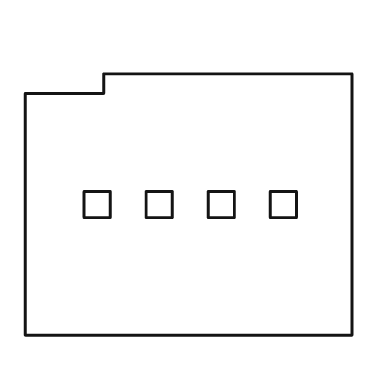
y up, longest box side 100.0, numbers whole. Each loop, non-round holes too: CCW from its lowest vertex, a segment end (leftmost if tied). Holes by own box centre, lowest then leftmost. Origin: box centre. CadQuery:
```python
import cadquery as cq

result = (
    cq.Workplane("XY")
    .moveTo(-50.0, -40.0)
    .lineTo(50.0, -40.0)
    .lineTo(50.0, 40.0)
    .lineTo(-26.0, 40.0)
    .lineTo(-26.0, 34.0)
    .lineTo(-50.0, 34.0)
    .close()
    .moveTo(-32.0, -4.0)
    .lineTo(-24.0, -4.0)
    .lineTo(-24.0, 4.0)
    .lineTo(-32.0, 4.0)
    .close()
    .moveTo(-13.0, -4.0)
    .lineTo(-5.0, -4.0)
    .lineTo(-5.0, 4.0)
    .lineTo(-13.0, 4.0)
    .close()
    .moveTo(6.0, -4.0)
    .lineTo(14.0, -4.0)
    .lineTo(14.0, 4.0)
    .lineTo(6.0, 4.0)
    .close()
    .moveTo(25.0, -4.0)
    .lineTo(33.0, -4.0)
    .lineTo(33.0, 4.0)
    .lineTo(25.0, 4.0)
    .close()
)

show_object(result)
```